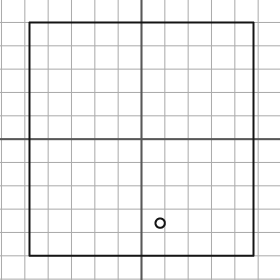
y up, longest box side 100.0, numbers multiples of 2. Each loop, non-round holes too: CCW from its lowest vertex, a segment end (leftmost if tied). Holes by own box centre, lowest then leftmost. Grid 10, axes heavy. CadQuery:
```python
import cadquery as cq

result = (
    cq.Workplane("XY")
    .moveTo(-48.0, -50.0)
    .lineTo(48.0, -50.0)
    .lineTo(48.0, 50.0)
    .lineTo(-48.0, 50.0)
    .close()
    .moveTo(8.0, -36.0)
    .circle(2.0)
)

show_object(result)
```